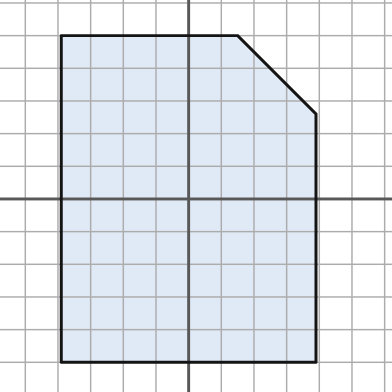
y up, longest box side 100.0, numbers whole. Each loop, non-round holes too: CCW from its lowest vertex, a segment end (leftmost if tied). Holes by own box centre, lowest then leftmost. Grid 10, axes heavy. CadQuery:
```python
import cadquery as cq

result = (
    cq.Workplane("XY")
    .moveTo(-39.0, -50.0)
    .lineTo(39.0, -50.0)
    .lineTo(39.0, 26.0)
    .lineTo(15.0, 50.0)
    .lineTo(-39.0, 50.0)
    .close()
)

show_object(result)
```